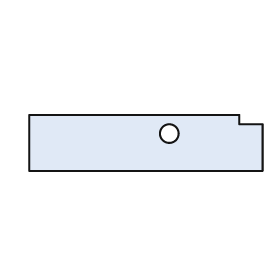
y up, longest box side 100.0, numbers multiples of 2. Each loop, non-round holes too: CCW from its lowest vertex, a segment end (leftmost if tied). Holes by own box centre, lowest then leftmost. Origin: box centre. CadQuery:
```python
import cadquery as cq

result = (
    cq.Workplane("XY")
    .moveTo(-50.0, -12.0)
    .lineTo(50.0, -12.0)
    .lineTo(50.0, 8.0)
    .lineTo(40.0, 8.0)
    .lineTo(40.0, 12.0)
    .lineTo(-50.0, 12.0)
    .close()
    .moveTo(10.0, 4.0)
    .circle(4.0)
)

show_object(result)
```